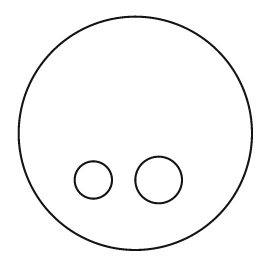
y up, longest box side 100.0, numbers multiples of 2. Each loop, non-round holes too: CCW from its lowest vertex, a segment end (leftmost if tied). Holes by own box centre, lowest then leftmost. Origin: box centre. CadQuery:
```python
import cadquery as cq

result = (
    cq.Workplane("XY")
    .moveTo(0.0, 0.0)
    .circle(50.0)
    .moveTo(-18.0, -20.0)
    .circle(8.0)
    .moveTo(10.0, -20.0)
    .circle(10.0)
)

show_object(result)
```